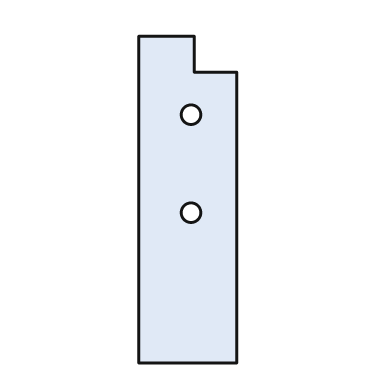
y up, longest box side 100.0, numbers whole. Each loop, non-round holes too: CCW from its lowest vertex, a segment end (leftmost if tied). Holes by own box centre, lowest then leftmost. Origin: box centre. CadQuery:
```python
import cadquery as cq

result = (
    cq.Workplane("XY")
    .moveTo(-15.0, -50.0)
    .lineTo(15.0, -50.0)
    .lineTo(15.0, 39.0)
    .lineTo(2.0, 39.0)
    .lineTo(2.0, 50.0)
    .lineTo(-15.0, 50.0)
    .close()
    .moveTo(1.0, -4.0)
    .circle(3.0)
    .moveTo(1.0, 26.0)
    .circle(3.0)
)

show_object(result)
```